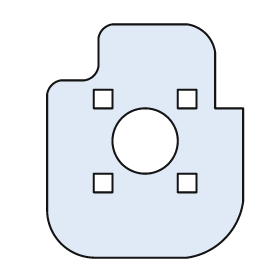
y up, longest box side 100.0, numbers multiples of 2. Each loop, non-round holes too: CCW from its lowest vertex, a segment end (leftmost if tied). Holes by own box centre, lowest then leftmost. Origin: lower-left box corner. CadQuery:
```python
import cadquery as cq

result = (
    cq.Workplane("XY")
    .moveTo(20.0, 0.0)
    .lineTo(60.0, 0.0)
    .threePointArc((76.0, 8.0), (84.0, 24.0))
    .lineTo(84.0, 64.0)
    .lineTo(72.0, 64.0)
    .lineTo(72.0, 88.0)
    .threePointArc((68.0, 96.0), (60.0, 100.0))
    .lineTo(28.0, 100.0)
    .threePointArc((24.0, 98.0), (22.0, 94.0))
    .lineTo(22.0, 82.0)
    .threePointArc((20.0, 78.0), (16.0, 76.0))
    .lineTo(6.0, 76.0)
    .threePointArc((2.0, 74.0), (0.0, 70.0))
    .lineTo(0.0, 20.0)
    .threePointArc((6.0, 6.0), (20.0, 0.0))
    .close()
    .moveTo(20.0, 28.0)
    .lineTo(28.0, 28.0)
    .lineTo(28.0, 36.0)
    .lineTo(20.0, 36.0)
    .close()
    .moveTo(56.0, 28.0)
    .lineTo(64.0, 28.0)
    .lineTo(64.0, 36.0)
    .lineTo(56.0, 36.0)
    .close()
    .moveTo(42.0, 50.0)
    .circle(14.0)
    .moveTo(20.0, 64.0)
    .lineTo(28.0, 64.0)
    .lineTo(28.0, 72.0)
    .lineTo(20.0, 72.0)
    .close()
    .moveTo(56.0, 64.0)
    .lineTo(64.0, 64.0)
    .lineTo(64.0, 72.0)
    .lineTo(56.0, 72.0)
    .close()
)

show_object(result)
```